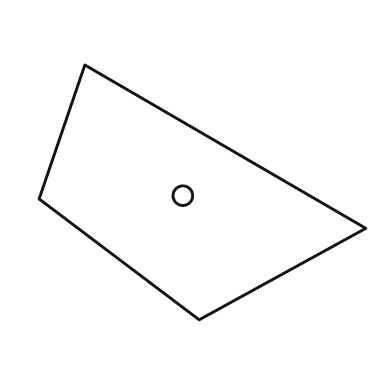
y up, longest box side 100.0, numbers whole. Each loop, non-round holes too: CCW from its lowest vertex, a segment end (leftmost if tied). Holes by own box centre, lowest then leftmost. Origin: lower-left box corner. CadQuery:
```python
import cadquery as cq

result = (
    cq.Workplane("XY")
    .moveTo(49.0, 0.0)
    .lineTo(100.0, 28.0)
    .lineTo(14.0, 78.0)
    .lineTo(0.0, 37.0)
    .close()
    .moveTo(44.0, 38.0)
    .circle(3.0)
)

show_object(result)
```